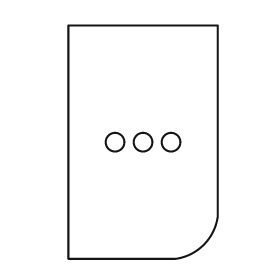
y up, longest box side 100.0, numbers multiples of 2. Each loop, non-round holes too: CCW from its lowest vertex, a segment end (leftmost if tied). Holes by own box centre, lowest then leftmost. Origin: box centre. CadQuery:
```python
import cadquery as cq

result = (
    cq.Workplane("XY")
    .moveTo(-32.0, -50.0)
    .lineTo(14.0, -50.0)
    .threePointArc((26.0, -44.0), (32.0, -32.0))
    .lineTo(32.0, 50.0)
    .lineTo(-32.0, 50.0)
    .close()
    .moveTo(-12.0, 0.0)
    .circle(4.0)
    .moveTo(0.0, 0.0)
    .circle(4.0)
    .moveTo(12.0, 0.0)
    .circle(4.0)
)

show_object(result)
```